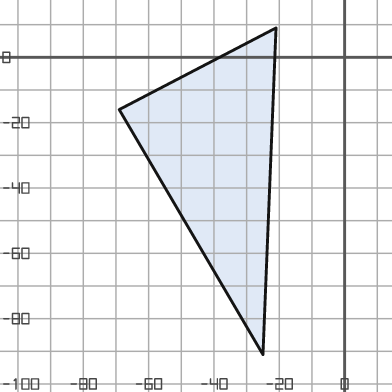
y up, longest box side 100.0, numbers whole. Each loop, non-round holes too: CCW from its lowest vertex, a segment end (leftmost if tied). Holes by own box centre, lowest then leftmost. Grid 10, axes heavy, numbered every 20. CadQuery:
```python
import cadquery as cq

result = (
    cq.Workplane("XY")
    .moveTo(-25.0, -91.0)
    .lineTo(-21.0, 9.0)
    .lineTo(-69.0, -16.0)
    .close()
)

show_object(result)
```